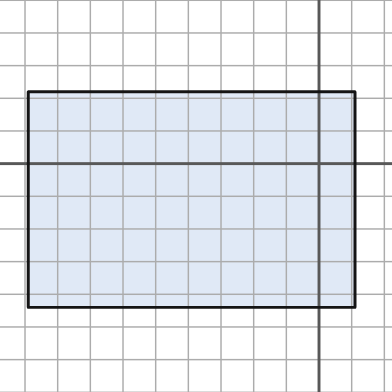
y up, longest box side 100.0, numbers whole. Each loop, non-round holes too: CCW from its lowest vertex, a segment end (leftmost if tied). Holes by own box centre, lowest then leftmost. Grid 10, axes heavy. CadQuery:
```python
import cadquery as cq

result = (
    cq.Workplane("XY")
    .moveTo(-89.0, -44.0)
    .lineTo(11.0, -44.0)
    .lineTo(11.0, 22.0)
    .lineTo(-89.0, 22.0)
    .close()
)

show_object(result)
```